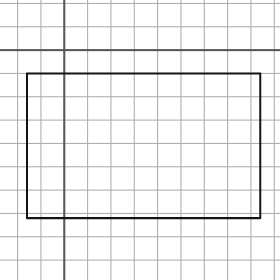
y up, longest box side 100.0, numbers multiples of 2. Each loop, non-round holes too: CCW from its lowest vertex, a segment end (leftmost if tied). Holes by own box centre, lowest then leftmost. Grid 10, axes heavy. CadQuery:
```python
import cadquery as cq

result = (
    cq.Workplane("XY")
    .moveTo(-16.0, -72.0)
    .lineTo(84.0, -72.0)
    .lineTo(84.0, -10.0)
    .lineTo(-16.0, -10.0)
    .close()
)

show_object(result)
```